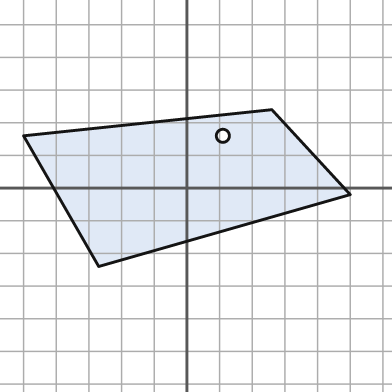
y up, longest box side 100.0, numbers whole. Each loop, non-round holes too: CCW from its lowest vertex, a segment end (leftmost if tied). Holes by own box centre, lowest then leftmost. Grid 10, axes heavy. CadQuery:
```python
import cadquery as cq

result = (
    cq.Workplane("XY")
    .moveTo(-27.0, -24.0)
    .lineTo(50.0, -2.0)
    .lineTo(26.0, 24.0)
    .lineTo(-50.0, 16.0)
    .close()
    .moveTo(11.0, 16.0)
    .circle(2.0)
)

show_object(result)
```